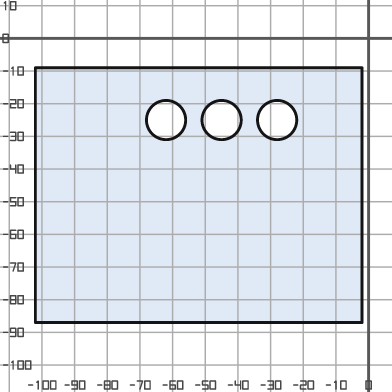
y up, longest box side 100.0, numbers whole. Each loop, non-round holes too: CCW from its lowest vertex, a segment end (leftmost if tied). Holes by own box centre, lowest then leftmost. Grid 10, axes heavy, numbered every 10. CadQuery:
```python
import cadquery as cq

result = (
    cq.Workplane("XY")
    .moveTo(-102.0, -87.0)
    .lineTo(-2.0, -87.0)
    .lineTo(-2.0, -9.0)
    .lineTo(-102.0, -9.0)
    .close()
    .moveTo(-62.0, -25.0)
    .circle(6.0)
    .moveTo(-45.0, -25.0)
    .circle(6.0)
    .moveTo(-28.0, -25.0)
    .circle(6.0)
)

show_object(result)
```